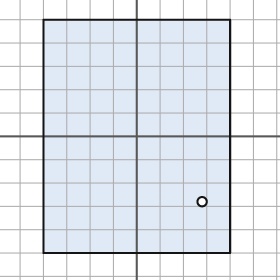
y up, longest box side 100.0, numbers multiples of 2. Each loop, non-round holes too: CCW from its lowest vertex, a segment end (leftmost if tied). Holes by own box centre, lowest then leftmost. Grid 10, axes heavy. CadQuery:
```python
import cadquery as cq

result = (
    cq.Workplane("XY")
    .moveTo(-40.0, -50.0)
    .lineTo(40.0, -50.0)
    .lineTo(40.0, 50.0)
    .lineTo(-40.0, 50.0)
    .close()
    .moveTo(28.0, -28.0)
    .circle(2.0)
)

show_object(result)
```